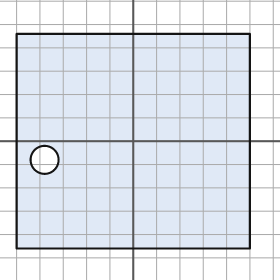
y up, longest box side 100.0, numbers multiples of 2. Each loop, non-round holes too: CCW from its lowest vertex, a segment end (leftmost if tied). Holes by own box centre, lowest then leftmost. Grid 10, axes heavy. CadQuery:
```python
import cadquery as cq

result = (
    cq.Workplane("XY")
    .moveTo(-50.0, -46.0)
    .lineTo(50.0, -46.0)
    .lineTo(50.0, 46.0)
    .lineTo(-50.0, 46.0)
    .close()
    .moveTo(-38.0, -8.0)
    .circle(6.0)
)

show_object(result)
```